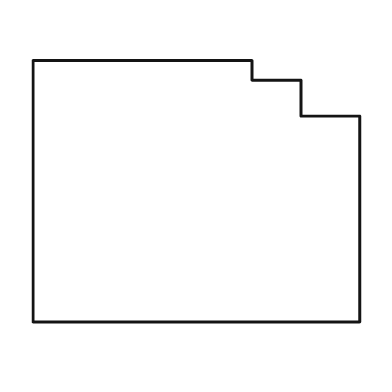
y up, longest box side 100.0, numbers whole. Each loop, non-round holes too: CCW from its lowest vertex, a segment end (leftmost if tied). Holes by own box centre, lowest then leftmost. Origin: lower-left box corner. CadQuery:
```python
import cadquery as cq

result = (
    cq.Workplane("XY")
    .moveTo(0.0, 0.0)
    .lineTo(100.0, 0.0)
    .lineTo(100.0, 63.0)
    .lineTo(82.0, 63.0)
    .lineTo(82.0, 74.0)
    .lineTo(67.0, 74.0)
    .lineTo(67.0, 80.0)
    .lineTo(0.0, 80.0)
    .close()
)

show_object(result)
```